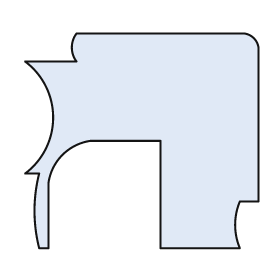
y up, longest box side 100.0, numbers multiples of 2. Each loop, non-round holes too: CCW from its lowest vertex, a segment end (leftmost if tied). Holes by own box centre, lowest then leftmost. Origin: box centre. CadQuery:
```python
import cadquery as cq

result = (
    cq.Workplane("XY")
    .moveTo(-44.0, -46.0)
    .lineTo(-40.0, -46.0)
    .lineTo(-40.0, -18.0)
    .threePointArc((-34.0, -6.0), (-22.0, 0.0))
    .lineTo(8.0, 0.0)
    .lineTo(8.0, -46.0)
    .lineTo(42.0, -46.0)
    .threePointArc((40.0, -36.0), (42.0, -26.0))
    .lineTo(50.0, -26.0)
    .lineTo(50.0, 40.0)
    .threePointArc((48.0, 44.0), (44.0, 46.0))
    .lineTo(-28.0, 46.0)
    .threePointArc((-30.0, 40.0), (-28.0, 34.0))
    .lineTo(-50.0, 34.0)
    .threePointArc((-38.0, 10.0), (-50.0, -14.0))
    .lineTo(-44.0, -14.0)
    .threePointArc((-46.0, -30.0), (-44.0, -46.0))
    .close()
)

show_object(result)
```